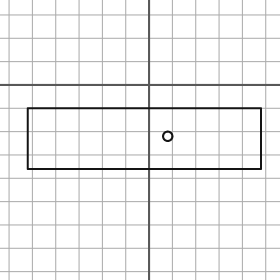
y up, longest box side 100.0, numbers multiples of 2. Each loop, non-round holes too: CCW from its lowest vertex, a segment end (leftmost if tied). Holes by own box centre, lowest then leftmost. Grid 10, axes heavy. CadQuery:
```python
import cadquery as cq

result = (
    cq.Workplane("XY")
    .moveTo(-52.0, -36.0)
    .lineTo(48.0, -36.0)
    .lineTo(48.0, -10.0)
    .lineTo(-52.0, -10.0)
    .close()
    .moveTo(8.0, -22.0)
    .circle(2.0)
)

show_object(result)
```